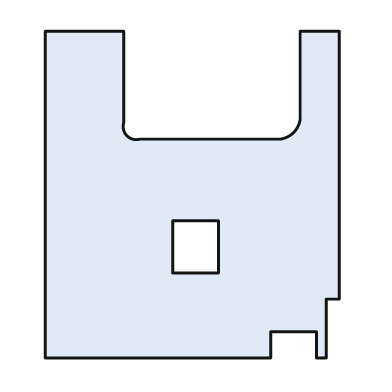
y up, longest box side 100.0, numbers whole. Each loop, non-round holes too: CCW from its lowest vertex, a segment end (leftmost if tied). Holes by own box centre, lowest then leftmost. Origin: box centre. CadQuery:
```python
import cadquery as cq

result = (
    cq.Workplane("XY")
    .moveTo(-45.0, -50.0)
    .lineTo(24.0, -50.0)
    .lineTo(24.0, -42.0)
    .lineTo(38.0, -42.0)
    .lineTo(38.0, -50.0)
    .lineTo(41.0, -50.0)
    .lineTo(41.0, -32.0)
    .lineTo(45.0, -32.0)
    .lineTo(45.0, 50.0)
    .lineTo(33.0, 50.0)
    .lineTo(33.0, 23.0)
    .threePointArc((31.0, 19.0), (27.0, 17.0))
    .lineTo(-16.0, 17.0)
    .threePointArc((-20.0, 18.0), (-21.0, 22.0))
    .lineTo(-21.0, 50.0)
    .lineTo(-45.0, 50.0)
    .close()
    .moveTo(-6.0, -24.0)
    .lineTo(8.0, -24.0)
    .lineTo(8.0, -8.0)
    .lineTo(-6.0, -8.0)
    .close()
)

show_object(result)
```